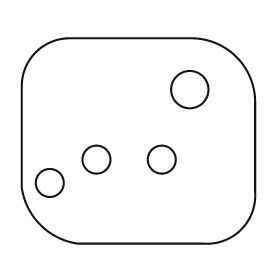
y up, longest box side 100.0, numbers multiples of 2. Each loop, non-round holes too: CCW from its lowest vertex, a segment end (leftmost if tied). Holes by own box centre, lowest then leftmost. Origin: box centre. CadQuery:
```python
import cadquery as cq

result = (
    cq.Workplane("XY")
    .moveTo(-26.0, -44.0)
    .lineTo(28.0, -44.0)
    .threePointArc((44.0, -38.0), (50.0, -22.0))
    .lineTo(50.0, 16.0)
    .threePointArc((42.0, 36.0), (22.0, 44.0))
    .lineTo(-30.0, 44.0)
    .threePointArc((-44.0, 38.0), (-50.0, 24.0))
    .lineTo(-50.0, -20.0)
    .threePointArc((-42.0, -36.0), (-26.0, -44.0))
    .close()
    .moveTo(-38.0, -18.0)
    .circle(6.0)
    .moveTo(-18.0, -8.0)
    .circle(6.0)
    .moveTo(10.0, -8.0)
    .circle(6.0)
    .moveTo(22.0, 22.0)
    .circle(8.0)
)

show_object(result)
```